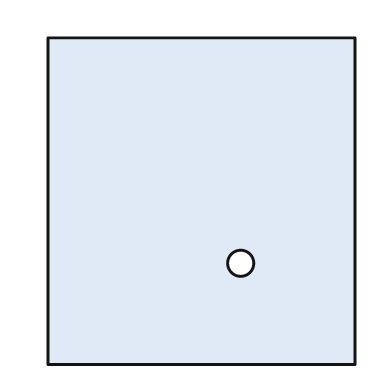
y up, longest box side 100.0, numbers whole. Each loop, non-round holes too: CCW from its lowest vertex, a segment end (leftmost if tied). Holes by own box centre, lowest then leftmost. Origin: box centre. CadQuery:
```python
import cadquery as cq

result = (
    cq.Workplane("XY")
    .moveTo(-47.0, -50.0)
    .lineTo(47.0, -50.0)
    .lineTo(47.0, 50.0)
    .lineTo(-47.0, 50.0)
    .close()
    .moveTo(12.0, -19.0)
    .circle(4.0)
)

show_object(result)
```